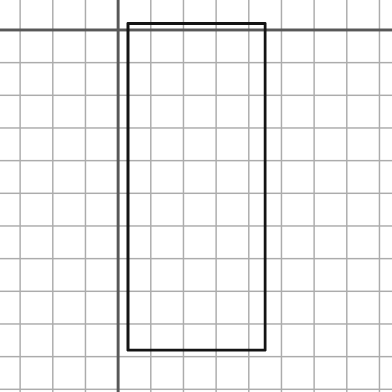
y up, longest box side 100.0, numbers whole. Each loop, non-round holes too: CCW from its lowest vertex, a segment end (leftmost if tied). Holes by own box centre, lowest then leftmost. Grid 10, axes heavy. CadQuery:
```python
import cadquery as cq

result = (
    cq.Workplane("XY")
    .moveTo(3.0, -98.0)
    .lineTo(45.0, -98.0)
    .lineTo(45.0, 2.0)
    .lineTo(3.0, 2.0)
    .close()
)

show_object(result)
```